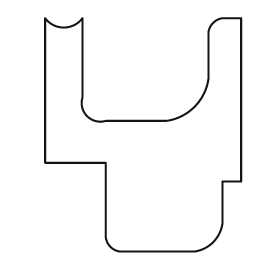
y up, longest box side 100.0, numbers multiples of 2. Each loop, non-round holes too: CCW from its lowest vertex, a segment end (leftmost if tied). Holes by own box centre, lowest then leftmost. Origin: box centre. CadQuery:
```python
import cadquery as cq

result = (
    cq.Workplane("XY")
    .moveTo(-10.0, -50.0)
    .lineTo(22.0, -50.0)
    .threePointArc((30.0, -46.0), (34.0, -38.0))
    .lineTo(34.0, -20.0)
    .lineTo(42.0, -20.0)
    .lineTo(42.0, 50.0)
    .lineTo(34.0, 50.0)
    .threePointArc((30.0, 48.0), (28.0, 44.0))
    .lineTo(28.0, 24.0)
    .threePointArc((22.0, 12.0), (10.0, 6.0))
    .lineTo(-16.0, 6.0)
    .threePointArc((-24.0, 8.0), (-26.0, 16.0))
    .lineTo(-26.0, 50.0)
    .threePointArc((-34.0, 46.0), (-42.0, 50.0))
    .lineTo(-42.0, -12.0)
    .lineTo(-16.0, -12.0)
    .lineTo(-16.0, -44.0)
    .threePointArc((-14.0, -48.0), (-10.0, -50.0))
    .close()
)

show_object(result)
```